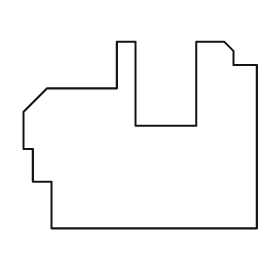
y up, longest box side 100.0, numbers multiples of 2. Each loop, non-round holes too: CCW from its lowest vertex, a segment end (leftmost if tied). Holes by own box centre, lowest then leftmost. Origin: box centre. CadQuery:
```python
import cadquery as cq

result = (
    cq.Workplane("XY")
    .moveTo(-38.0, -40.0)
    .lineTo(50.0, -40.0)
    .lineTo(50.0, 30.0)
    .lineTo(40.0, 30.0)
    .lineTo(40.0, 36.0)
    .lineTo(36.0, 40.0)
    .lineTo(24.0, 40.0)
    .lineTo(24.0, 4.0)
    .lineTo(-2.0, 4.0)
    .lineTo(-2.0, 40.0)
    .lineTo(-10.0, 40.0)
    .lineTo(-10.0, 20.0)
    .lineTo(-40.0, 20.0)
    .lineTo(-50.0, 10.0)
    .lineTo(-50.0, -6.0)
    .lineTo(-46.0, -6.0)
    .lineTo(-46.0, -20.0)
    .lineTo(-38.0, -20.0)
    .close()
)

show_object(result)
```